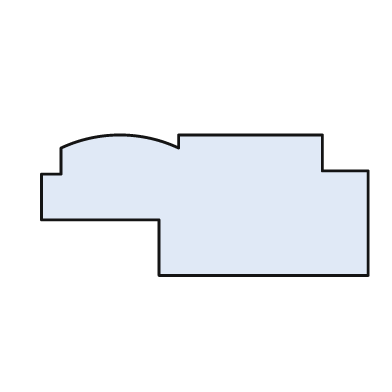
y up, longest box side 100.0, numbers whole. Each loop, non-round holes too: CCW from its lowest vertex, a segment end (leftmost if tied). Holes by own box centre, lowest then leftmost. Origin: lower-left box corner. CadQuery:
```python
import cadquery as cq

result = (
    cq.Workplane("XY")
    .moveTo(36.0, 0.0)
    .lineTo(100.0, 0.0)
    .lineTo(100.0, 32.0)
    .lineTo(86.0, 32.0)
    .lineTo(86.0, 43.0)
    .lineTo(42.0, 43.0)
    .lineTo(42.0, 39.0)
    .threePointArc((24.0, 43.0), (6.0, 39.0))
    .lineTo(6.0, 31.0)
    .lineTo(0.0, 31.0)
    .lineTo(0.0, 17.0)
    .lineTo(36.0, 17.0)
    .close()
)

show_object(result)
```